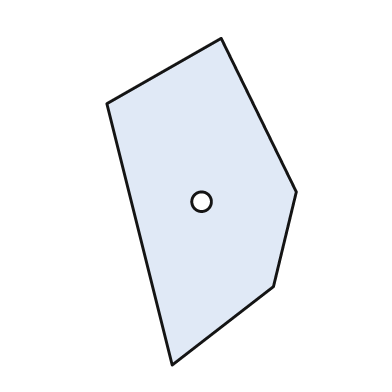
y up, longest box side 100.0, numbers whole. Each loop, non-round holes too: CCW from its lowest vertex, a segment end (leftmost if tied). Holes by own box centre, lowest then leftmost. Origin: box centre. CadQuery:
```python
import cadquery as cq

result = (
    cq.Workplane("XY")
    .moveTo(-9.0, -50.0)
    .lineTo(22.0, -26.0)
    .lineTo(29.0, 3.0)
    .lineTo(6.0, 50.0)
    .lineTo(-29.0, 30.0)
    .close()
    .moveTo(0.0, 0.0)
    .circle(3.0)
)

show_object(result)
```